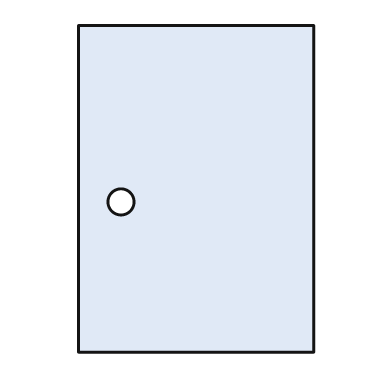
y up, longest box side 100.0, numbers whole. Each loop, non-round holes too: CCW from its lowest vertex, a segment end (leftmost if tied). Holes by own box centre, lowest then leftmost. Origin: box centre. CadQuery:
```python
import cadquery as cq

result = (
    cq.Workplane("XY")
    .moveTo(-36.0, -50.0)
    .lineTo(36.0, -50.0)
    .lineTo(36.0, 50.0)
    .lineTo(-36.0, 50.0)
    .close()
    .moveTo(-23.0, -4.0)
    .circle(4.0)
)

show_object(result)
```